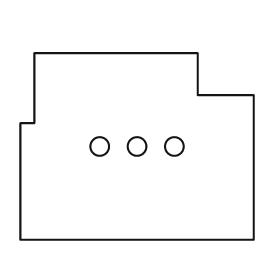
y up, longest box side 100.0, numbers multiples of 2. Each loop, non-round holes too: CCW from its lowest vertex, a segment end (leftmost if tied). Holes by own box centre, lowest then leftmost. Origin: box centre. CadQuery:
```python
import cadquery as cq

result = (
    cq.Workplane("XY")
    .moveTo(-50.0, -40.0)
    .lineTo(50.0, -40.0)
    .lineTo(50.0, 22.0)
    .lineTo(26.0, 22.0)
    .lineTo(26.0, 40.0)
    .lineTo(-44.0, 40.0)
    .lineTo(-44.0, 10.0)
    .lineTo(-50.0, 10.0)
    .close()
    .moveTo(-16.0, 0.0)
    .circle(4.0)
    .moveTo(0.0, 0.0)
    .circle(4.0)
    .moveTo(16.0, 0.0)
    .circle(4.0)
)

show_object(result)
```